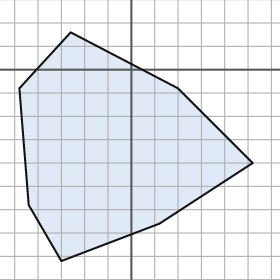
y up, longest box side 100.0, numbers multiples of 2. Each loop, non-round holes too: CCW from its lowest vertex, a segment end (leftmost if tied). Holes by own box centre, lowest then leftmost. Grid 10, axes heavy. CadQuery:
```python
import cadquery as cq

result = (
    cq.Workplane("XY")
    .moveTo(-30.0, -82.0)
    .lineTo(12.0, -66.0)
    .lineTo(52.0, -40.0)
    .lineTo(20.0, -8.0)
    .lineTo(-26.0, 16.0)
    .lineTo(-48.0, -8.0)
    .lineTo(-44.0, -58.0)
    .close()
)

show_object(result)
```